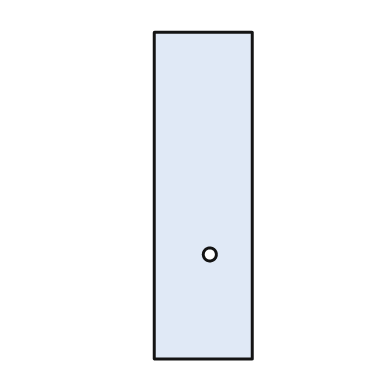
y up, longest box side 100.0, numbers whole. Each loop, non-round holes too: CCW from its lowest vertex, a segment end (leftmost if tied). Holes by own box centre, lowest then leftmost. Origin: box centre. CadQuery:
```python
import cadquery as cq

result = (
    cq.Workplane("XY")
    .moveTo(-15.0, -50.0)
    .lineTo(15.0, -50.0)
    .lineTo(15.0, 50.0)
    .lineTo(-15.0, 50.0)
    .close()
    .moveTo(2.0, -18.0)
    .circle(2.0)
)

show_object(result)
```